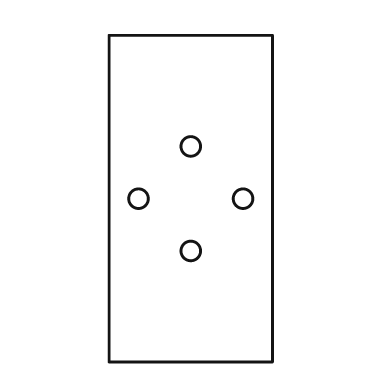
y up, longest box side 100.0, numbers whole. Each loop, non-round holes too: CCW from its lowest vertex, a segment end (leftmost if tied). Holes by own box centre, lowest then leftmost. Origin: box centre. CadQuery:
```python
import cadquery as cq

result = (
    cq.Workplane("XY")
    .moveTo(-25.0, -50.0)
    .lineTo(25.0, -50.0)
    .lineTo(25.0, 50.0)
    .lineTo(-25.0, 50.0)
    .close()
    .moveTo(0.0, -16.0)
    .circle(3.0)
    .moveTo(-16.0, 0.0)
    .circle(3.0)
    .moveTo(16.0, 0.0)
    .circle(3.0)
    .moveTo(0.0, 16.0)
    .circle(3.0)
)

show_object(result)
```